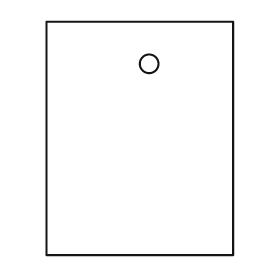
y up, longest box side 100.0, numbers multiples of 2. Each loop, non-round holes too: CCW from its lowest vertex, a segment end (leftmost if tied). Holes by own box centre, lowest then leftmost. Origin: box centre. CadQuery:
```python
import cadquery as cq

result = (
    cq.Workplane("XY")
    .moveTo(-40.0, -50.0)
    .lineTo(40.0, -50.0)
    .lineTo(40.0, 50.0)
    .lineTo(-40.0, 50.0)
    .close()
    .moveTo(4.0, 32.0)
    .circle(4.0)
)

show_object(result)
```